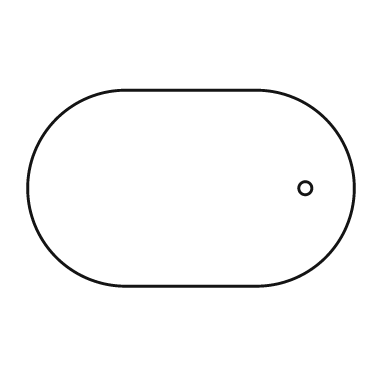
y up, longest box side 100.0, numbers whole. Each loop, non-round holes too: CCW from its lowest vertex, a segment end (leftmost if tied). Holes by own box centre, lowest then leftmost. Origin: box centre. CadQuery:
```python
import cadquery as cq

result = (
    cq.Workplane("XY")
    .moveTo(-20.0, -30.0)
    .lineTo(20.0, -30.0)
    .threePointArc((50.0, 0.0), (20.0, 30.0))
    .lineTo(-20.0, 30.0)
    .threePointArc((-50.0, 0.0), (-20.0, -30.0))
    .close()
    .moveTo(35.0, 0.0)
    .circle(2.0)
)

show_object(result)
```